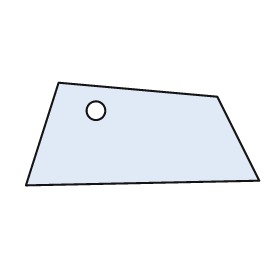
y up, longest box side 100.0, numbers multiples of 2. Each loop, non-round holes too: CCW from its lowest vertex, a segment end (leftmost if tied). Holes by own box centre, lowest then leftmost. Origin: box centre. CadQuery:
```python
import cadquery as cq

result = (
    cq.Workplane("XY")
    .moveTo(-50.0, -22.0)
    .lineTo(50.0, -20.0)
    .lineTo(32.0, 16.0)
    .lineTo(-36.0, 22.0)
    .close()
    .moveTo(-20.0, 10.0)
    .circle(4.0)
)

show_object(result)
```